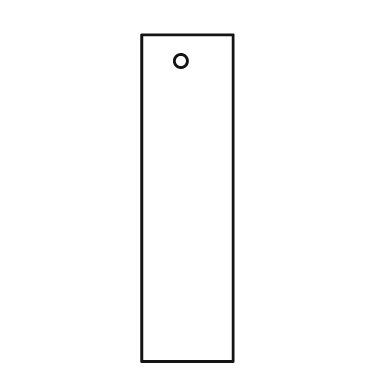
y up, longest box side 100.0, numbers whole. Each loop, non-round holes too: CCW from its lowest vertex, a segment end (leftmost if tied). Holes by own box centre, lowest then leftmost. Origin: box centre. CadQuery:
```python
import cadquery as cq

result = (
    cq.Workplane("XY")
    .moveTo(-14.0, -50.0)
    .lineTo(14.0, -50.0)
    .lineTo(14.0, 50.0)
    .lineTo(-14.0, 50.0)
    .close()
    .moveTo(-2.0, 42.0)
    .circle(2.0)
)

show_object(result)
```